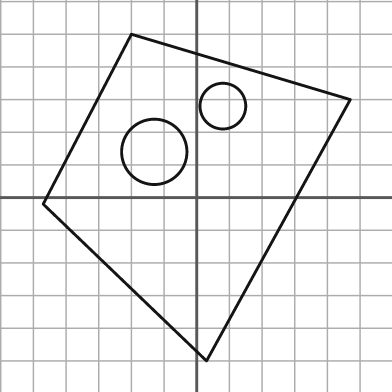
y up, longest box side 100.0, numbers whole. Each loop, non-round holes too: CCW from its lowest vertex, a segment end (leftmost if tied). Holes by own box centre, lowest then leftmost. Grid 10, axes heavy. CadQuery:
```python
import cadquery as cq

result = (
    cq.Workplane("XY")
    .moveTo(3.0, -50.0)
    .lineTo(47.0, 30.0)
    .lineTo(-20.0, 50.0)
    .lineTo(-47.0, -2.0)
    .close()
    .moveTo(-13.0, 14.0)
    .circle(10.0)
    .moveTo(8.0, 28.0)
    .circle(7.0)
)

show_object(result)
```